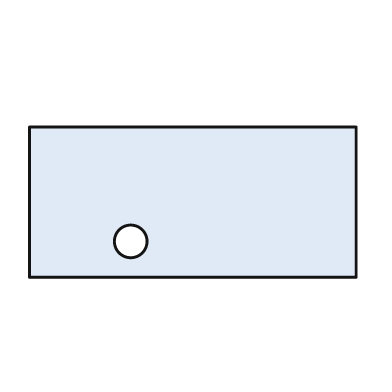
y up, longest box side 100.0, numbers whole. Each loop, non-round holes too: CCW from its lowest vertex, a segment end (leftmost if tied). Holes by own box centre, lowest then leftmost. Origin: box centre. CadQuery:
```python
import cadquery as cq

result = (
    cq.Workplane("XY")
    .moveTo(-50.0, -23.0)
    .lineTo(50.0, -23.0)
    .lineTo(50.0, 23.0)
    .lineTo(-50.0, 23.0)
    .close()
    .moveTo(-19.0, -12.0)
    .circle(5.0)
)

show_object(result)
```